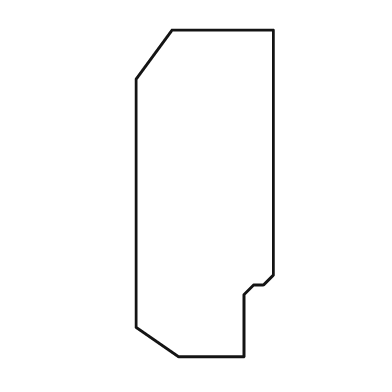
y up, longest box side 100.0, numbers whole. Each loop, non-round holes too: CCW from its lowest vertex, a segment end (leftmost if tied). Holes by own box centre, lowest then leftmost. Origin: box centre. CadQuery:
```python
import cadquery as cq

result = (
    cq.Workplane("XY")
    .moveTo(-8.0, -50.0)
    .lineTo(12.0, -50.0)
    .lineTo(12.0, -31.0)
    .lineTo(15.0, -28.0)
    .lineTo(18.0, -28.0)
    .lineTo(21.0, -25.0)
    .lineTo(21.0, 50.0)
    .lineTo(-10.0, 50.0)
    .lineTo(-21.0, 35.0)
    .lineTo(-21.0, -41.0)
    .close()
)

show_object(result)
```